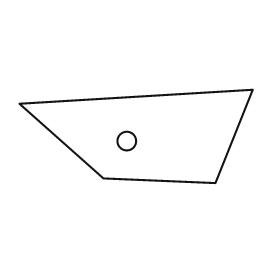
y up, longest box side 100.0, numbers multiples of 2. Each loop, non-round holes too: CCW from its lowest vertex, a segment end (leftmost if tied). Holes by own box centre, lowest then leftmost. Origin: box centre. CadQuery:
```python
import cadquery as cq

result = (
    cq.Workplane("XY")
    .moveTo(34.0, -20.0)
    .lineTo(50.0, 20.0)
    .lineTo(-50.0, 14.0)
    .lineTo(-14.0, -18.0)
    .close()
    .moveTo(-4.0, -2.0)
    .circle(4.0)
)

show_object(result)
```